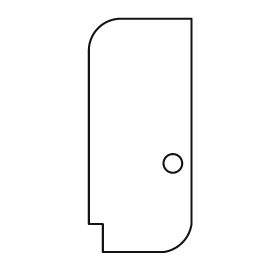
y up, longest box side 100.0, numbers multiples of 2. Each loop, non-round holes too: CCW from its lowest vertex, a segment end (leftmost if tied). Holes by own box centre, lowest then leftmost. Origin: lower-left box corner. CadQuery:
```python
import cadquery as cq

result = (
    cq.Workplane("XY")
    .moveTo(6.0, 0.0)
    .lineTo(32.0, 0.0)
    .threePointArc((40.0, 4.0), (44.0, 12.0))
    .lineTo(44.0, 100.0)
    .lineTo(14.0, 100.0)
    .threePointArc((4.0, 96.0), (0.0, 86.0))
    .lineTo(0.0, 12.0)
    .lineTo(6.0, 12.0)
    .close()
    .moveTo(36.0, 38.0)
    .circle(4.0)
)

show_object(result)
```